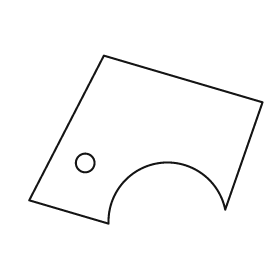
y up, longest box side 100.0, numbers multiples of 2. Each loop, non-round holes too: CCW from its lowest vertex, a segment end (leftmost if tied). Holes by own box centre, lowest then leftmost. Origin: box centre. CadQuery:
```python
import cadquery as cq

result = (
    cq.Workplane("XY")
    .moveTo(-16.0, -36.0)
    .threePointArc((6.0, -10.0), (34.0, -30.0))
    .lineTo(50.0, 16.0)
    .lineTo(-18.0, 36.0)
    .lineTo(-50.0, -26.0)
    .close()
    .moveTo(-26.0, -10.0)
    .circle(4.0)
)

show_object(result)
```